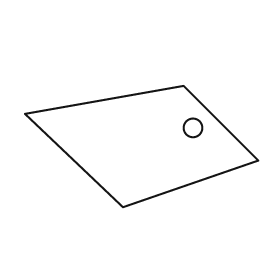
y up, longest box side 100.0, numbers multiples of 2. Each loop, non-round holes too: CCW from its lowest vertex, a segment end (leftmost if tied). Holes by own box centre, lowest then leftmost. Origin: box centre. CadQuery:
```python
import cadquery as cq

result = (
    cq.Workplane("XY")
    .moveTo(-8.0, -26.0)
    .lineTo(50.0, -6.0)
    .lineTo(18.0, 26.0)
    .lineTo(-50.0, 14.0)
    .close()
    .moveTo(22.0, 8.0)
    .circle(4.0)
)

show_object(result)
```